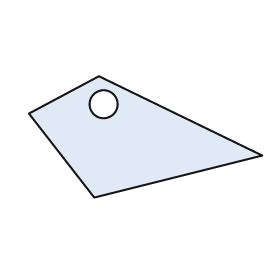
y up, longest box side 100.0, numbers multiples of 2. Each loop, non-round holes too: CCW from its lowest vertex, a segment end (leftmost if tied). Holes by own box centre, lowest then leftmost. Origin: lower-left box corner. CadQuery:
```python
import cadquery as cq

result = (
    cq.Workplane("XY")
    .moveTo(28.0, 0.0)
    .lineTo(100.0, 18.0)
    .lineTo(30.0, 52.0)
    .lineTo(0.0, 36.0)
    .close()
    .moveTo(32.0, 40.0)
    .circle(6.0)
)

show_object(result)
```